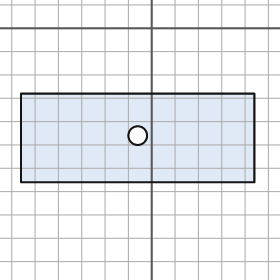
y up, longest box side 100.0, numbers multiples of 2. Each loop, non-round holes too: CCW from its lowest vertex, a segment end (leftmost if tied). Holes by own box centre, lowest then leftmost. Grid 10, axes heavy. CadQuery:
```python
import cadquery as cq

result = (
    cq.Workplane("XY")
    .moveTo(-56.0, -66.0)
    .lineTo(44.0, -66.0)
    .lineTo(44.0, -28.0)
    .lineTo(-56.0, -28.0)
    .close()
    .moveTo(-6.0, -46.0)
    .circle(4.0)
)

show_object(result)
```